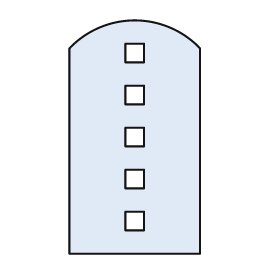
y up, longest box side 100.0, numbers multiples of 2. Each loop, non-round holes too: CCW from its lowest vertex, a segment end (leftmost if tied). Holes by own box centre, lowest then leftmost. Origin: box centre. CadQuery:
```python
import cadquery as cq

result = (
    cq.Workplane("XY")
    .moveTo(-28.0, -50.0)
    .lineTo(28.0, -50.0)
    .lineTo(28.0, 38.0)
    .threePointArc((0.0, 50.0), (-28.0, 38.0))
    .close()
    .moveTo(-4.0, -40.0)
    .lineTo(4.0, -40.0)
    .lineTo(4.0, -32.0)
    .lineTo(-4.0, -32.0)
    .close()
    .moveTo(-4.0, -22.0)
    .lineTo(4.0, -22.0)
    .lineTo(4.0, -14.0)
    .lineTo(-4.0, -14.0)
    .close()
    .moveTo(-4.0, -4.0)
    .lineTo(4.0, -4.0)
    .lineTo(4.0, 4.0)
    .lineTo(-4.0, 4.0)
    .close()
    .moveTo(-4.0, 14.0)
    .lineTo(4.0, 14.0)
    .lineTo(4.0, 22.0)
    .lineTo(-4.0, 22.0)
    .close()
    .moveTo(-4.0, 32.0)
    .lineTo(4.0, 32.0)
    .lineTo(4.0, 40.0)
    .lineTo(-4.0, 40.0)
    .close()
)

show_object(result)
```